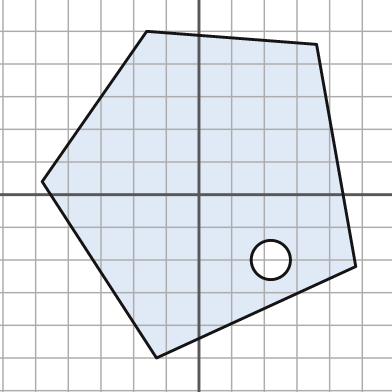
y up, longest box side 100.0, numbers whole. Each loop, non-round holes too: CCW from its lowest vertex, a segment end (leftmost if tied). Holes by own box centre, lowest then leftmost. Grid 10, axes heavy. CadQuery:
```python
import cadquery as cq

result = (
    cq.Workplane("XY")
    .moveTo(-13.0, -50.0)
    .lineTo(48.0, -22.0)
    .lineTo(36.0, 46.0)
    .lineTo(-16.0, 50.0)
    .lineTo(-48.0, 4.0)
    .close()
    .moveTo(22.0, -20.0)
    .circle(6.0)
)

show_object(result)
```